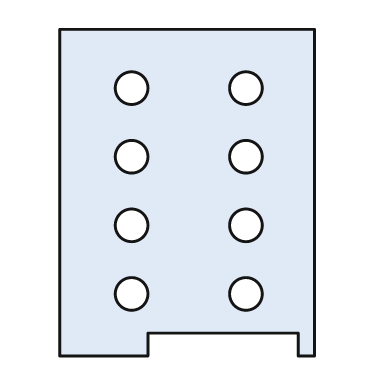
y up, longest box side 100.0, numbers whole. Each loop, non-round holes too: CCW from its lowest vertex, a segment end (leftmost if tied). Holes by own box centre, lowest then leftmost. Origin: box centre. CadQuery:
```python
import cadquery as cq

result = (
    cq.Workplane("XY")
    .moveTo(-39.0, -50.0)
    .lineTo(-12.0, -50.0)
    .lineTo(-12.0, -43.0)
    .lineTo(34.0, -43.0)
    .lineTo(34.0, -50.0)
    .lineTo(39.0, -50.0)
    .lineTo(39.0, 50.0)
    .lineTo(-39.0, 50.0)
    .close()
    .moveTo(-17.0, -31.0)
    .circle(5.0)
    .moveTo(18.0, -31.0)
    .circle(5.0)
    .moveTo(-17.0, -10.0)
    .circle(5.0)
    .moveTo(18.0, -10.0)
    .circle(5.0)
    .moveTo(-17.0, 11.0)
    .circle(5.0)
    .moveTo(18.0, 11.0)
    .circle(5.0)
    .moveTo(-17.0, 32.0)
    .circle(5.0)
    .moveTo(18.0, 32.0)
    .circle(5.0)
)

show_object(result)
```